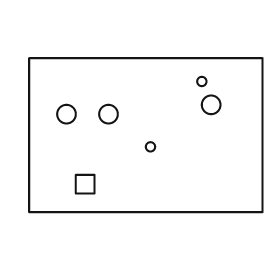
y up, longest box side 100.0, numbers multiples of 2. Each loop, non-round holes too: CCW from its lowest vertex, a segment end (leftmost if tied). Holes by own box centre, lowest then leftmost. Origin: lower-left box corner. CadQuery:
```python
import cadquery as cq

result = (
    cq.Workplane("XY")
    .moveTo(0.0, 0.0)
    .lineTo(100.0, 0.0)
    .lineTo(100.0, 66.0)
    .lineTo(0.0, 66.0)
    .close()
    .moveTo(20.0, 8.0)
    .lineTo(28.0, 8.0)
    .lineTo(28.0, 16.0)
    .lineTo(20.0, 16.0)
    .close()
    .moveTo(52.0, 28.0)
    .circle(2.0)
    .moveTo(16.0, 42.0)
    .circle(4.0)
    .moveTo(34.0, 42.0)
    .circle(4.0)
    .moveTo(78.0, 46.0)
    .circle(4.0)
    .moveTo(74.0, 56.0)
    .circle(2.0)
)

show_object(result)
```